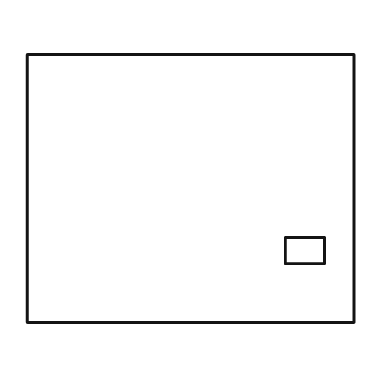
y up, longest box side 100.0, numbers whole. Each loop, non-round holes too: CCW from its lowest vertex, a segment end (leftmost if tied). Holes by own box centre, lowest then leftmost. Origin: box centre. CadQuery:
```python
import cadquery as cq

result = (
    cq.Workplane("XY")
    .moveTo(-50.0, -41.0)
    .lineTo(50.0, -41.0)
    .lineTo(50.0, 41.0)
    .lineTo(-50.0, 41.0)
    .close()
    .moveTo(29.0, -23.0)
    .lineTo(41.0, -23.0)
    .lineTo(41.0, -15.0)
    .lineTo(29.0, -15.0)
    .close()
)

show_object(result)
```